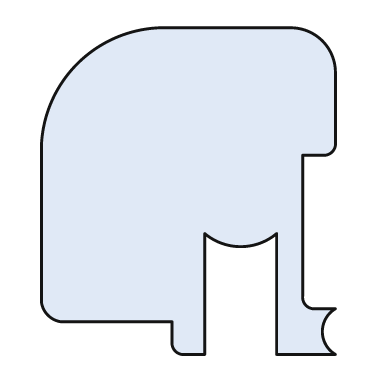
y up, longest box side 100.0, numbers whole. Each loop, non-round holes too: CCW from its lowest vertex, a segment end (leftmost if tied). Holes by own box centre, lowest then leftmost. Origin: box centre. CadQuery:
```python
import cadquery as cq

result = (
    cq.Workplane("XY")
    .moveTo(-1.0, -50.0)
    .lineTo(5.0, -50.0)
    .lineTo(5.0, -13.0)
    .threePointArc((16.0, -17.0), (27.0, -13.0))
    .lineTo(27.0, -50.0)
    .lineTo(45.0, -50.0)
    .threePointArc((41.0, -43.0), (45.0, -36.0))
    .lineTo(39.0, -36.0)
    .threePointArc((36.0, -35.0), (35.0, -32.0))
    .lineTo(35.0, 11.0)
    .lineTo(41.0, 11.0)
    .threePointArc((44.0, 12.0), (45.0, 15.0))
    .lineTo(45.0, 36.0)
    .threePointArc((41.0, 46.0), (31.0, 50.0))
    .lineTo(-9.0, 50.0)
    .threePointArc((-34.0, 39.0), (-45.0, 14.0))
    .lineTo(-45.0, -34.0)
    .threePointArc((-43.0, -38.0), (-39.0, -40.0))
    .lineTo(-5.0, -40.0)
    .lineTo(-5.0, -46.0)
    .threePointArc((-4.0, -49.0), (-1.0, -50.0))
    .close()
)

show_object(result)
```